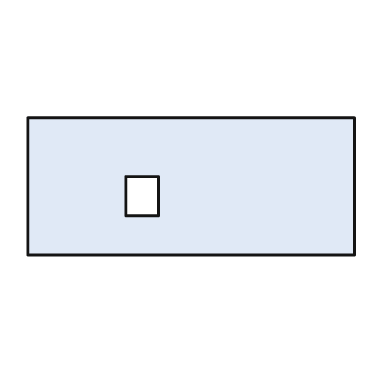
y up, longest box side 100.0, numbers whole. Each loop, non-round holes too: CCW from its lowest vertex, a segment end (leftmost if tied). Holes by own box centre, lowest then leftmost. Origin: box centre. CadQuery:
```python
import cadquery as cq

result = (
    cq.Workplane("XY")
    .moveTo(-50.0, -21.0)
    .lineTo(50.0, -21.0)
    .lineTo(50.0, 21.0)
    .lineTo(-50.0, 21.0)
    .close()
    .moveTo(-20.0, -9.0)
    .lineTo(-10.0, -9.0)
    .lineTo(-10.0, 3.0)
    .lineTo(-20.0, 3.0)
    .close()
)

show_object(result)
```